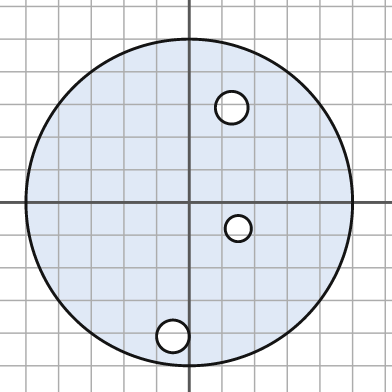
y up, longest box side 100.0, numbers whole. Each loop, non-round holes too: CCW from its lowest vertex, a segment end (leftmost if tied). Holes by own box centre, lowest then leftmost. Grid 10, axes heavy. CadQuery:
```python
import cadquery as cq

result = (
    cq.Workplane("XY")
    .moveTo(0.0, 0.0)
    .circle(50.0)
    .moveTo(-5.0, -41.0)
    .circle(5.0)
    .moveTo(15.0, -8.0)
    .circle(4.0)
    .moveTo(13.0, 29.0)
    .circle(5.0)
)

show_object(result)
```